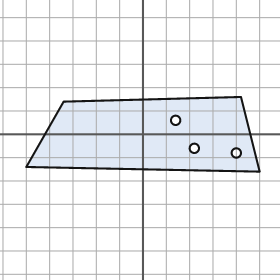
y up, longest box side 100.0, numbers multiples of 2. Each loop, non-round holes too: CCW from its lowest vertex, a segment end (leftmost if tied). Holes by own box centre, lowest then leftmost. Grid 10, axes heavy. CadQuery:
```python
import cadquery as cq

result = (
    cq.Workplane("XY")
    .moveTo(50.0, -16.0)
    .lineTo(42.0, 16.0)
    .lineTo(-34.0, 14.0)
    .lineTo(-50.0, -14.0)
    .close()
    .moveTo(40.0, -8.0)
    .circle(2.0)
    .moveTo(22.0, -6.0)
    .circle(2.0)
    .moveTo(14.0, 6.0)
    .circle(2.0)
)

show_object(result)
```